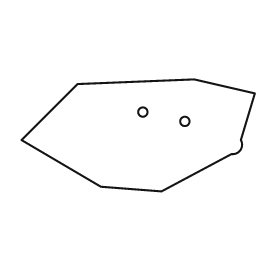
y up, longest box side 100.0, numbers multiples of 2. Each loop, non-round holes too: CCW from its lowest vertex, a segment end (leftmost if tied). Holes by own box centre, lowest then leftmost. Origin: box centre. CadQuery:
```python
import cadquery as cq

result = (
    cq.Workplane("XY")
    .moveTo(10.0, -24.0)
    .lineTo(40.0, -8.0)
    .threePointArc((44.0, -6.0), (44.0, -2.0))
    .lineTo(50.0, 18.0)
    .lineTo(24.0, 24.0)
    .lineTo(-26.0, 22.0)
    .lineTo(-50.0, -2.0)
    .lineTo(-16.0, -22.0)
    .close()
    .moveTo(20.0, 6.0)
    .circle(2.0)
    .moveTo(2.0, 10.0)
    .circle(2.0)
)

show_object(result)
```